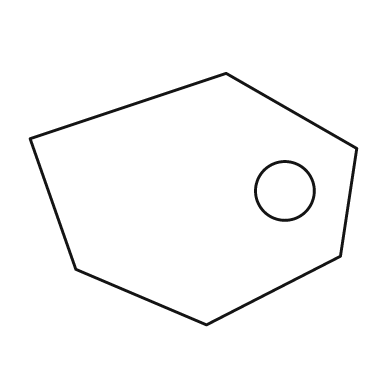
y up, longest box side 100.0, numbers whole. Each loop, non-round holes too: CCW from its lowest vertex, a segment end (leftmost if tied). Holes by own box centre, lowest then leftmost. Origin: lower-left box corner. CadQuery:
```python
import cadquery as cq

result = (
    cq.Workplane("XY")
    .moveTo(54.0, 0.0)
    .lineTo(95.0, 21.0)
    .lineTo(100.0, 54.0)
    .lineTo(60.0, 77.0)
    .lineTo(0.0, 57.0)
    .lineTo(14.0, 17.0)
    .close()
    .moveTo(78.0, 41.0)
    .circle(9.0)
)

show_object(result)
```